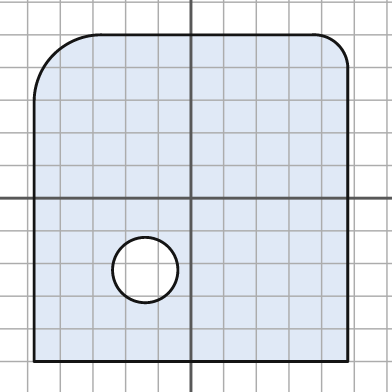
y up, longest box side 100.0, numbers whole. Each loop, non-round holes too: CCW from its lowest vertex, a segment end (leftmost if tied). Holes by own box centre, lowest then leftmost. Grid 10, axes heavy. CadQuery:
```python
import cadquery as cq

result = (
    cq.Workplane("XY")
    .moveTo(-48.0, -50.0)
    .lineTo(48.0, -50.0)
    .lineTo(48.0, 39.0)
    .threePointArc((45.0, 47.0), (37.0, 50.0))
    .lineTo(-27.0, 50.0)
    .threePointArc((-42.0, 44.0), (-48.0, 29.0))
    .close()
    .moveTo(-14.0, -22.0)
    .circle(10.0)
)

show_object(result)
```